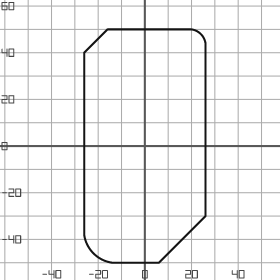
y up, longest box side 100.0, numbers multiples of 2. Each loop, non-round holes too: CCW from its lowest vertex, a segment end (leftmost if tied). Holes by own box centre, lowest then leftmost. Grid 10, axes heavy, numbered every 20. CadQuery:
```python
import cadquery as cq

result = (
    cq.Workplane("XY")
    .moveTo(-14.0, -50.0)
    .lineTo(6.0, -50.0)
    .lineTo(26.0, -30.0)
    .lineTo(26.0, 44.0)
    .threePointArc((24.0, 48.0), (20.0, 50.0))
    .lineTo(-16.0, 50.0)
    .lineTo(-26.0, 40.0)
    .lineTo(-26.0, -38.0)
    .threePointArc((-22.0, -46.0), (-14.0, -50.0))
    .close()
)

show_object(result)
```